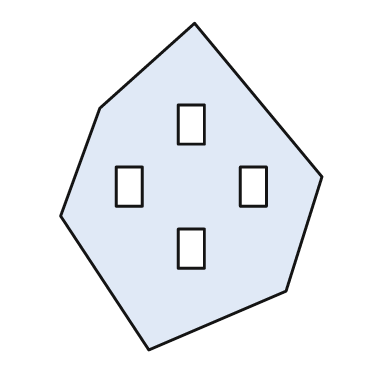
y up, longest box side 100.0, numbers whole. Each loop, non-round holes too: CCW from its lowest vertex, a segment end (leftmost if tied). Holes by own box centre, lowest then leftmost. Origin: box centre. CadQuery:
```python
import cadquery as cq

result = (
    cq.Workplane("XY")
    .moveTo(-13.0, -50.0)
    .lineTo(29.0, -32.0)
    .lineTo(40.0, 3.0)
    .lineTo(1.0, 50.0)
    .lineTo(-28.0, 24.0)
    .lineTo(-40.0, -9.0)
    .close()
    .moveTo(-4.0, -25.0)
    .lineTo(4.0, -25.0)
    .lineTo(4.0, -13.0)
    .lineTo(-4.0, -13.0)
    .close()
    .moveTo(-23.0, -6.0)
    .lineTo(-15.0, -6.0)
    .lineTo(-15.0, 6.0)
    .lineTo(-23.0, 6.0)
    .close()
    .moveTo(15.0, -6.0)
    .lineTo(23.0, -6.0)
    .lineTo(23.0, 6.0)
    .lineTo(15.0, 6.0)
    .close()
    .moveTo(-4.0, 13.0)
    .lineTo(4.0, 13.0)
    .lineTo(4.0, 25.0)
    .lineTo(-4.0, 25.0)
    .close()
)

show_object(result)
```